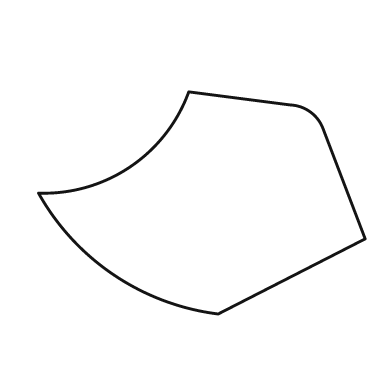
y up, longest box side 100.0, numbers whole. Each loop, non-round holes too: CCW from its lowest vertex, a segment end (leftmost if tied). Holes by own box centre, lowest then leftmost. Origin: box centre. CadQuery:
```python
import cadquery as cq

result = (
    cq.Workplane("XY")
    .moveTo(5.0, -34.0)
    .lineTo(50.0, -11.0)
    .lineTo(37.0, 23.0)
    .threePointArc((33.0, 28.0), (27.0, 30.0))
    .lineTo(-4.0, 34.0)
    .threePointArc((-22.0, 11.0), (-50.0, 3.0))
    .threePointArc((-27.0, -22.0), (5.0, -34.0))
    .close()
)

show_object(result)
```